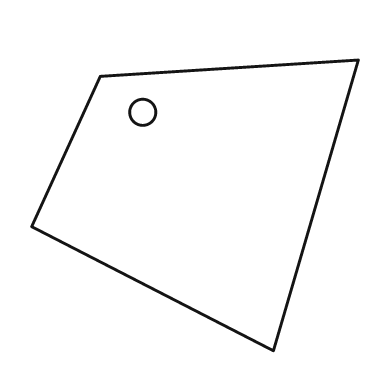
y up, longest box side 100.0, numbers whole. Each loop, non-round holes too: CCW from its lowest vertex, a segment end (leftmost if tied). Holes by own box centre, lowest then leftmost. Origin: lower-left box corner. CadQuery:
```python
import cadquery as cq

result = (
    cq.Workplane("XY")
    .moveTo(74.0, 0.0)
    .lineTo(100.0, 89.0)
    .lineTo(21.0, 84.0)
    .lineTo(0.0, 38.0)
    .close()
    .moveTo(34.0, 73.0)
    .circle(4.0)
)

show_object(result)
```